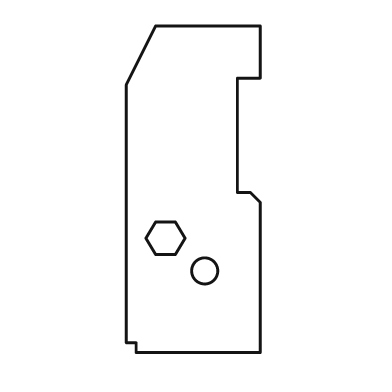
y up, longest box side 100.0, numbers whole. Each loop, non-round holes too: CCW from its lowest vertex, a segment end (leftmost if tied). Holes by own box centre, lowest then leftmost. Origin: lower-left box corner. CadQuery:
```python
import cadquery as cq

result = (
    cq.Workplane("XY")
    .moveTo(3.0, 0.0)
    .lineTo(41.0, 0.0)
    .lineTo(41.0, 46.0)
    .lineTo(38.0, 49.0)
    .lineTo(34.0, 49.0)
    .lineTo(34.0, 84.0)
    .lineTo(41.0, 84.0)
    .lineTo(41.0, 100.0)
    .lineTo(9.0, 100.0)
    .lineTo(0.0, 82.0)
    .lineTo(0.0, 3.0)
    .lineTo(3.0, 3.0)
    .close()
    .moveTo(24.0, 25.0)
    .circle(4.0)
    .moveTo(9.0, 30.0)
    .lineTo(15.0, 30.0)
    .lineTo(18.0, 35.0)
    .lineTo(15.0, 40.0)
    .lineTo(9.0, 40.0)
    .lineTo(6.0, 35.0)
    .close()
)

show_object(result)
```